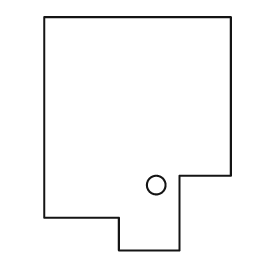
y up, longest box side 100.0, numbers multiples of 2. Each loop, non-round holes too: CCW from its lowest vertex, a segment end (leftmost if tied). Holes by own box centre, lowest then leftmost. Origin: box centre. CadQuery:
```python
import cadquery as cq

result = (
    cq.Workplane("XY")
    .moveTo(-8.0, -50.0)
    .lineTo(18.0, -50.0)
    .lineTo(18.0, -18.0)
    .lineTo(40.0, -18.0)
    .lineTo(40.0, 50.0)
    .lineTo(-40.0, 50.0)
    .lineTo(-40.0, -36.0)
    .lineTo(-8.0, -36.0)
    .close()
    .moveTo(8.0, -22.0)
    .circle(4.0)
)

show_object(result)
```